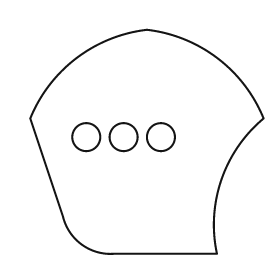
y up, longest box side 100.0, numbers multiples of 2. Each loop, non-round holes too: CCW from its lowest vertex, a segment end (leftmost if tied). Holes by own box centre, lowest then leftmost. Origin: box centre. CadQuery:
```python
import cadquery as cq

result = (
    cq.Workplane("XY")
    .moveTo(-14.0, -48.0)
    .lineTo(30.0, -48.0)
    .threePointArc((32.0, -16.0), (50.0, 10.0))
    .threePointArc((30.0, 36.0), (0.0, 48.0))
    .threePointArc((-30.0, 36.0), (-50.0, 10.0))
    .lineTo(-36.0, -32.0)
    .threePointArc((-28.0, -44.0), (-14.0, -48.0))
    .close()
    .moveTo(-26.0, 2.0)
    .circle(6.0)
    .moveTo(-10.0, 2.0)
    .circle(6.0)
    .moveTo(6.0, 2.0)
    .circle(6.0)
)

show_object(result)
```